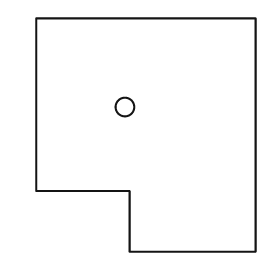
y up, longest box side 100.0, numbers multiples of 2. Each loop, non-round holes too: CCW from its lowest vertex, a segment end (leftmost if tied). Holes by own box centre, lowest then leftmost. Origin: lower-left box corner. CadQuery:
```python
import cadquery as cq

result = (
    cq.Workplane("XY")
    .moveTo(40.0, 0.0)
    .lineTo(94.0, 0.0)
    .lineTo(94.0, 100.0)
    .lineTo(0.0, 100.0)
    .lineTo(0.0, 26.0)
    .lineTo(40.0, 26.0)
    .close()
    .moveTo(38.0, 62.0)
    .circle(4.0)
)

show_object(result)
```